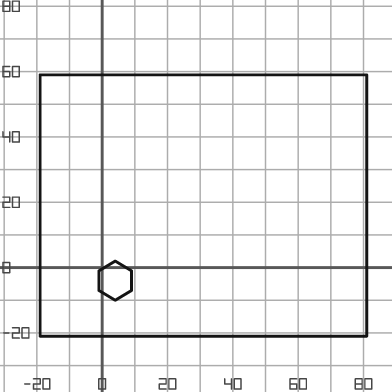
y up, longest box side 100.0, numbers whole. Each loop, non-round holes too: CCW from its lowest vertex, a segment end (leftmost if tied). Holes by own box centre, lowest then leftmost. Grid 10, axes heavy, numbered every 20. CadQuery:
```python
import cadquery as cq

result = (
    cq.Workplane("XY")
    .moveTo(-19.0, -21.0)
    .lineTo(81.0, -21.0)
    .lineTo(81.0, 59.0)
    .lineTo(-19.0, 59.0)
    .close()
    .moveTo(4.0, -10.0)
    .lineTo(9.0, -7.0)
    .lineTo(9.0, -1.0)
    .lineTo(4.0, 2.0)
    .lineTo(-1.0, -1.0)
    .lineTo(-1.0, -7.0)
    .close()
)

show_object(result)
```